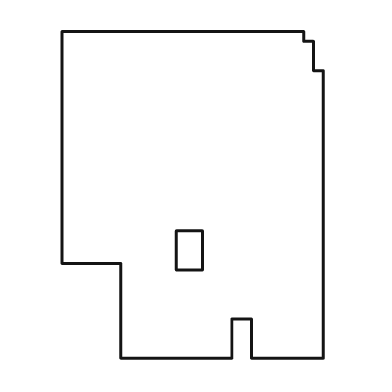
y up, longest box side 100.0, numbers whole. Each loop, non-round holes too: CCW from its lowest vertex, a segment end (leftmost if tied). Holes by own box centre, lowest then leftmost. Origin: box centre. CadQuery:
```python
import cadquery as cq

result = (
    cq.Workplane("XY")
    .moveTo(-22.0, -50.0)
    .lineTo(12.0, -50.0)
    .lineTo(12.0, -38.0)
    .lineTo(18.0, -38.0)
    .lineTo(18.0, -50.0)
    .lineTo(40.0, -50.0)
    .lineTo(40.0, 38.0)
    .lineTo(37.0, 38.0)
    .lineTo(37.0, 47.0)
    .lineTo(34.0, 47.0)
    .lineTo(34.0, 50.0)
    .lineTo(-40.0, 50.0)
    .lineTo(-40.0, -21.0)
    .lineTo(-22.0, -21.0)
    .close()
    .moveTo(-5.0, -23.0)
    .lineTo(3.0, -23.0)
    .lineTo(3.0, -11.0)
    .lineTo(-5.0, -11.0)
    .close()
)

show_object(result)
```